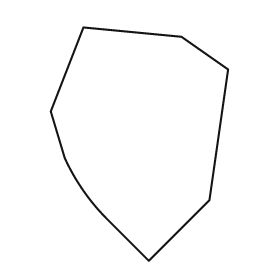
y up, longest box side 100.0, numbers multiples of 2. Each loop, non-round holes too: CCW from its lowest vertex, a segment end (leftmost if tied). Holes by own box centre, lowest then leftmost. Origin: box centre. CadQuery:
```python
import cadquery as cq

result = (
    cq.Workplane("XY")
    .moveTo(4.0, -50.0)
    .lineTo(30.0, -24.0)
    .lineTo(38.0, 32.0)
    .lineTo(18.0, 46.0)
    .lineTo(-24.0, 50.0)
    .lineTo(-38.0, 14.0)
    .lineTo(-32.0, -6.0)
    .threePointArc((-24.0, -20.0), (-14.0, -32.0))
    .close()
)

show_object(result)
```